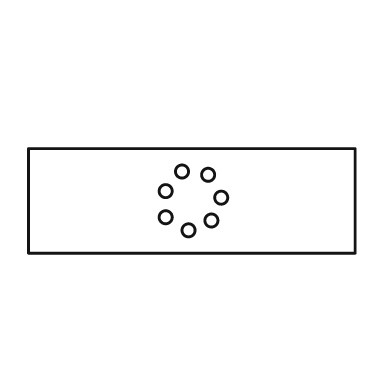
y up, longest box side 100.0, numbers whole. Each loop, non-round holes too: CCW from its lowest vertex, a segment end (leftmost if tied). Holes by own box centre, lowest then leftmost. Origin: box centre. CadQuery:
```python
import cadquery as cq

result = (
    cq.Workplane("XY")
    .moveTo(-50.0, -16.0)
    .lineTo(50.0, -16.0)
    .lineTo(50.0, 16.0)
    .lineTo(-50.0, 16.0)
    .close()
    .moveTo(-1.0, -9.0)
    .circle(2.0)
    .moveTo(6.0, -6.0)
    .circle(2.0)
    .moveTo(-8.0, -5.0)
    .circle(2.0)
    .moveTo(9.0, 1.0)
    .circle(2.0)
    .moveTo(-8.0, 3.0)
    .circle(2.0)
    .moveTo(5.0, 8.0)
    .circle(2.0)
    .moveTo(-3.0, 9.0)
    .circle(2.0)
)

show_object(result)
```